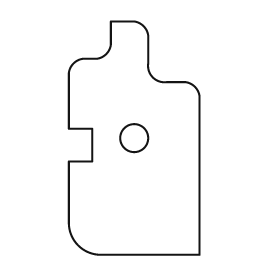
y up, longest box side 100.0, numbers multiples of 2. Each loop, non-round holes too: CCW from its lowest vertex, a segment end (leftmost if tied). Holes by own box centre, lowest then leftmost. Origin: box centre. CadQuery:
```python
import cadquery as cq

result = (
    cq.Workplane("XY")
    .moveTo(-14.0, -50.0)
    .lineTo(28.0, -50.0)
    .lineTo(28.0, 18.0)
    .threePointArc((26.0, 22.0), (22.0, 24.0))
    .lineTo(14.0, 24.0)
    .threePointArc((8.0, 26.0), (6.0, 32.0))
    .lineTo(6.0, 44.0)
    .threePointArc((4.0, 48.0), (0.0, 50.0))
    .lineTo(-10.0, 50.0)
    .lineTo(-10.0, 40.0)
    .threePointArc((-12.0, 36.0), (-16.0, 34.0))
    .lineTo(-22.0, 34.0)
    .threePointArc((-26.0, 32.0), (-28.0, 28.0))
    .lineTo(-28.0, 4.0)
    .lineTo(-18.0, 4.0)
    .lineTo(-18.0, -10.0)
    .lineTo(-28.0, -10.0)
    .lineTo(-28.0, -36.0)
    .threePointArc((-24.0, -46.0), (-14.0, -50.0))
    .close()
    .moveTo(0.0, 0.0)
    .circle(6.0)
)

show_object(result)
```